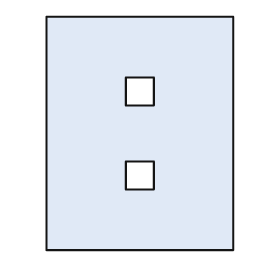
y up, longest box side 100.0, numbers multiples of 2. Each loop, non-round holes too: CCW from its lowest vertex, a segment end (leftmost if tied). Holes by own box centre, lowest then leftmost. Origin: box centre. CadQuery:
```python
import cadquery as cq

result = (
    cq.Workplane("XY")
    .moveTo(-40.0, -50.0)
    .lineTo(40.0, -50.0)
    .lineTo(40.0, 50.0)
    .lineTo(-40.0, 50.0)
    .close()
    .moveTo(-6.0, -24.0)
    .lineTo(6.0, -24.0)
    .lineTo(6.0, -12.0)
    .lineTo(-6.0, -12.0)
    .close()
    .moveTo(-6.0, 12.0)
    .lineTo(6.0, 12.0)
    .lineTo(6.0, 24.0)
    .lineTo(-6.0, 24.0)
    .close()
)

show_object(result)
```